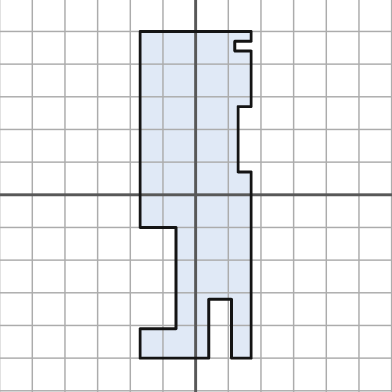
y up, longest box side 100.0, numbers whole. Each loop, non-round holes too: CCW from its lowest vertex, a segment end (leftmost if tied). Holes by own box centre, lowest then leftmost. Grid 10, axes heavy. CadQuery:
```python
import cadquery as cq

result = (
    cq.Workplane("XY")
    .moveTo(-17.0, -50.0)
    .lineTo(4.0, -50.0)
    .lineTo(4.0, -32.0)
    .lineTo(11.0, -32.0)
    .lineTo(11.0, -50.0)
    .lineTo(17.0, -50.0)
    .lineTo(17.0, 7.0)
    .lineTo(13.0, 7.0)
    .lineTo(13.0, 27.0)
    .lineTo(17.0, 27.0)
    .lineTo(17.0, 44.0)
    .lineTo(12.0, 44.0)
    .lineTo(12.0, 47.0)
    .lineTo(17.0, 47.0)
    .lineTo(17.0, 50.0)
    .lineTo(-17.0, 50.0)
    .lineTo(-17.0, -10.0)
    .lineTo(-6.0, -10.0)
    .lineTo(-6.0, -41.0)
    .lineTo(-17.0, -41.0)
    .close()
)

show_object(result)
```